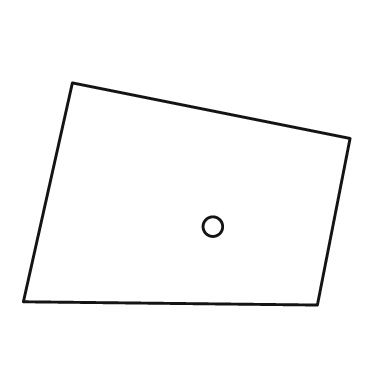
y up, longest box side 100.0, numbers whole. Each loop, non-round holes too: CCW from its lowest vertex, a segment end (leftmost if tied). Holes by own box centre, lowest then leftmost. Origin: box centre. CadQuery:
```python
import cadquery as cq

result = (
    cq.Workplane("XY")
    .moveTo(40.0, -34.0)
    .lineTo(50.0, 17.0)
    .lineTo(-35.0, 34.0)
    .lineTo(-50.0, -33.0)
    .close()
    .moveTo(8.0, -10.0)
    .circle(3.0)
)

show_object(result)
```